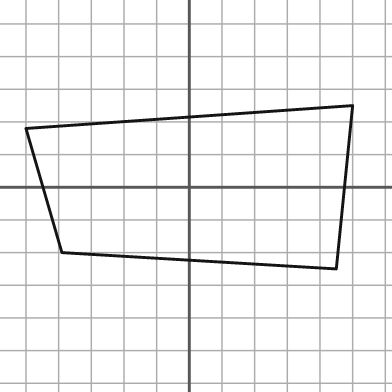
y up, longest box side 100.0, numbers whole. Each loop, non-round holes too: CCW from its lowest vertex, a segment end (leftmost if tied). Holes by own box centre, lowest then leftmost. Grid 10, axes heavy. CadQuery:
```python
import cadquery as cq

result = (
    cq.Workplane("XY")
    .moveTo(45.0, -25.0)
    .lineTo(50.0, 25.0)
    .lineTo(-50.0, 18.0)
    .lineTo(-39.0, -20.0)
    .close()
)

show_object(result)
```